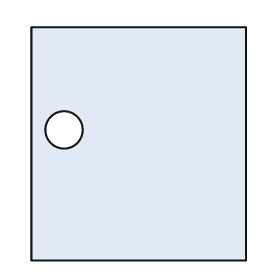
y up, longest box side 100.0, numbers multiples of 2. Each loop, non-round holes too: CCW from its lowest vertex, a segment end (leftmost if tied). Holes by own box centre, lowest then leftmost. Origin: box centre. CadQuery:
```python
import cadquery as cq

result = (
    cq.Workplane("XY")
    .moveTo(-46.0, -50.0)
    .lineTo(46.0, -50.0)
    .lineTo(46.0, 50.0)
    .lineTo(-46.0, 50.0)
    .close()
    .moveTo(-32.0, 6.0)
    .circle(8.0)
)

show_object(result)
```